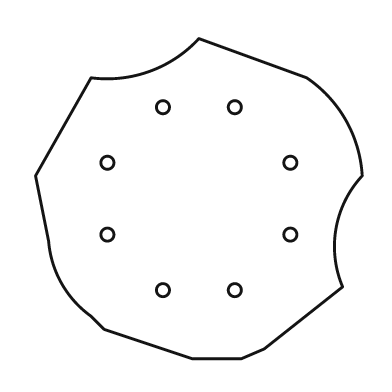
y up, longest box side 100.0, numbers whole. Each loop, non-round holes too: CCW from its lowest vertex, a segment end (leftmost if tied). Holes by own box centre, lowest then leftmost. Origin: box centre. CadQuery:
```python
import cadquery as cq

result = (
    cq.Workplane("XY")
    .moveTo(-2.0, -49.0)
    .lineTo(13.0, -49.0)
    .lineTo(20.0, -46.0)
    .lineTo(44.0, -27.0)
    .threePointArc((42.0, -9.0), (50.0, 7.0))
    .threePointArc((45.0, 24.0), (33.0, 37.0))
    .lineTo(0.0, 49.0)
    .threePointArc((-15.0, 39.0), (-33.0, 37.0))
    .lineTo(-50.0, 7.0)
    .lineTo(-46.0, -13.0)
    .threePointArc((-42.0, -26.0), (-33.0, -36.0))
    .lineTo(-29.0, -40.0)
    .close()
    .moveTo(-11.0, -28.0)
    .circle(2.0)
    .moveTo(11.0, -28.0)
    .circle(2.0)
    .moveTo(-28.0, -11.0)
    .circle(2.0)
    .moveTo(28.0, -11.0)
    .circle(2.0)
    .moveTo(-28.0, 11.0)
    .circle(2.0)
    .moveTo(28.0, 11.0)
    .circle(2.0)
    .moveTo(-11.0, 28.0)
    .circle(2.0)
    .moveTo(11.0, 28.0)
    .circle(2.0)
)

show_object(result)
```